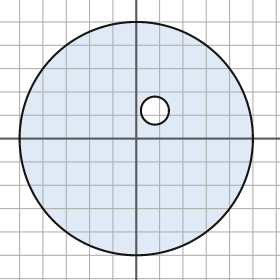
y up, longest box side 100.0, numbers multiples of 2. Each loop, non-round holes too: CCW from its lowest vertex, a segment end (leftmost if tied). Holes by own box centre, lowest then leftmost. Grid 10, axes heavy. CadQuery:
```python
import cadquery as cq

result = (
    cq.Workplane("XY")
    .moveTo(0.0, 0.0)
    .circle(50.0)
    .moveTo(8.0, 12.0)
    .circle(6.0)
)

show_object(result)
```